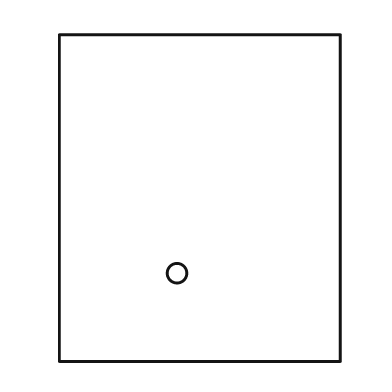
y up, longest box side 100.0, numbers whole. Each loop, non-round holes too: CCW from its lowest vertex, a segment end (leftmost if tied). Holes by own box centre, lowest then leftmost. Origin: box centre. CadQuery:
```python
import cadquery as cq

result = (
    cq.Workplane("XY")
    .moveTo(-43.0, -50.0)
    .lineTo(43.0, -50.0)
    .lineTo(43.0, 50.0)
    .lineTo(-43.0, 50.0)
    .close()
    .moveTo(-7.0, -23.0)
    .circle(3.0)
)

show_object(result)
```